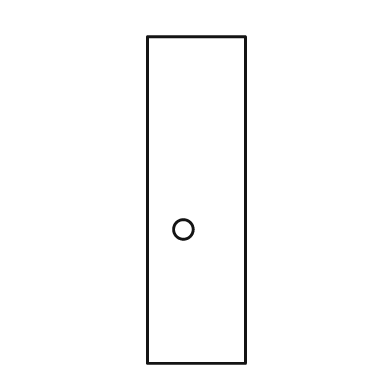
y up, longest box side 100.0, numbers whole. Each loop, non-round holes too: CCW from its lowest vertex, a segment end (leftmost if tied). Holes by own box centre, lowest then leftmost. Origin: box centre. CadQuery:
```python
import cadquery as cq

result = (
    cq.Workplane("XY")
    .moveTo(-15.0, -50.0)
    .lineTo(15.0, -50.0)
    .lineTo(15.0, 50.0)
    .lineTo(-15.0, 50.0)
    .close()
    .moveTo(-4.0, -9.0)
    .circle(3.0)
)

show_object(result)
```